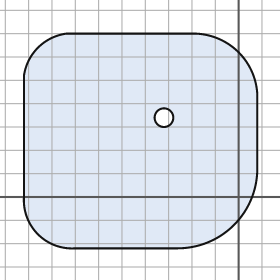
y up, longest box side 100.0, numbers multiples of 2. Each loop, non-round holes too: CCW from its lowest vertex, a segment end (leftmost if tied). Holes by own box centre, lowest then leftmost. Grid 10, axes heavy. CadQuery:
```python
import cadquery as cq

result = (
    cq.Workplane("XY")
    .moveTo(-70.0, -22.0)
    .lineTo(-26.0, -22.0)
    .threePointArc((-2.0, -12.0), (8.0, 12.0))
    .lineTo(8.0, 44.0)
    .threePointArc((0.0, 62.0), (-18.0, 70.0))
    .lineTo(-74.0, 70.0)
    .threePointArc((-86.0, 64.0), (-92.0, 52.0))
    .lineTo(-92.0, 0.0)
    .threePointArc((-86.0, -16.0), (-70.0, -22.0))
    .close()
    .moveTo(-32.0, 34.0)
    .circle(4.0)
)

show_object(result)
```